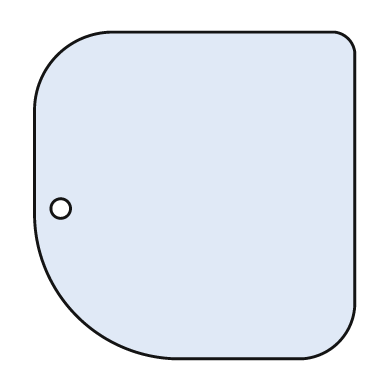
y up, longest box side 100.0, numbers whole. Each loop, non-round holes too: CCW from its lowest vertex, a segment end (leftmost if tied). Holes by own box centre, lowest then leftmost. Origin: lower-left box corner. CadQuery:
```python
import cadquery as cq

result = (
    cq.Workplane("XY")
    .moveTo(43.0, 0.0)
    .lineTo(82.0, 0.0)
    .threePointArc((93.0, 5.0), (98.0, 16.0))
    .lineTo(98.0, 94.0)
    .threePointArc((96.0, 98.0), (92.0, 100.0))
    .lineTo(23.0, 100.0)
    .threePointArc((7.0, 93.0), (0.0, 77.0))
    .lineTo(0.0, 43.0)
    .threePointArc((13.0, 13.0), (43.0, 0.0))
    .close()
    .moveTo(8.0, 46.0)
    .circle(3.0)
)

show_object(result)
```